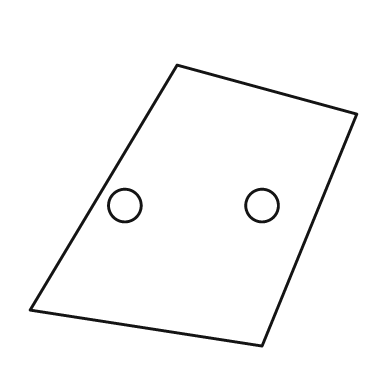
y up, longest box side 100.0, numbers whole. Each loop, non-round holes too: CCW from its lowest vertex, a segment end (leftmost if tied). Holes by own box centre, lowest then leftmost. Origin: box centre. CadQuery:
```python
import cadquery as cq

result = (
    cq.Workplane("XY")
    .moveTo(21.0, -43.0)
    .lineTo(50.0, 28.0)
    .lineTo(-5.0, 43.0)
    .lineTo(-50.0, -32.0)
    .close()
    .moveTo(-21.0, 0.0)
    .circle(5.0)
    .moveTo(21.0, 0.0)
    .circle(5.0)
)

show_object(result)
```